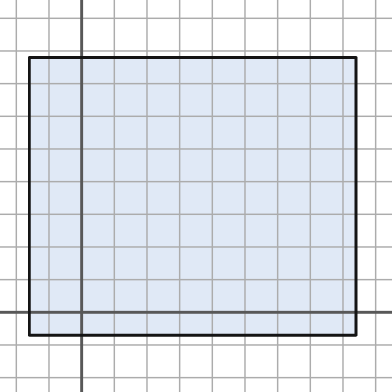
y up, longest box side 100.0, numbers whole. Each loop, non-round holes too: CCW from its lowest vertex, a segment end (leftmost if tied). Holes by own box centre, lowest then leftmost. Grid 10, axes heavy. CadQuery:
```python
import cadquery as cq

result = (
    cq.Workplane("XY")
    .moveTo(-16.0, -7.0)
    .lineTo(84.0, -7.0)
    .lineTo(84.0, 78.0)
    .lineTo(-16.0, 78.0)
    .close()
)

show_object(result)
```